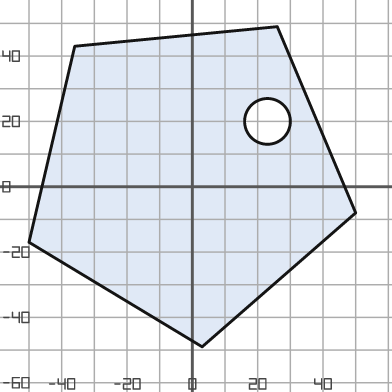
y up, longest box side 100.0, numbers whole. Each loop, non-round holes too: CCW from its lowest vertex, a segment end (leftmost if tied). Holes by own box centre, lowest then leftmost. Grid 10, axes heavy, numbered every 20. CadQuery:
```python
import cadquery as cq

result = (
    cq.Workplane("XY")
    .moveTo(3.0, -49.0)
    .lineTo(50.0, -8.0)
    .lineTo(26.0, 49.0)
    .lineTo(-36.0, 43.0)
    .lineTo(-50.0, -17.0)
    .close()
    .moveTo(23.0, 20.0)
    .circle(7.0)
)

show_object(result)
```